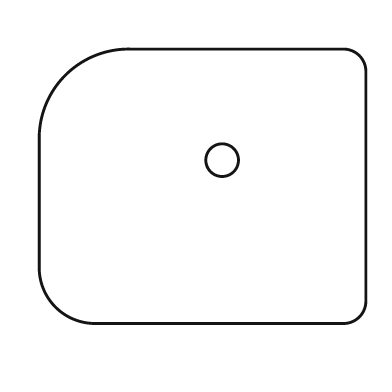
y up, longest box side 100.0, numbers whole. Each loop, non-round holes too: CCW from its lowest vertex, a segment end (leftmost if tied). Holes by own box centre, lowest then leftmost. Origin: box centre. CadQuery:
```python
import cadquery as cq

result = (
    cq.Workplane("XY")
    .moveTo(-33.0, -42.0)
    .lineTo(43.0, -42.0)
    .threePointArc((48.0, -40.0), (50.0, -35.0))
    .lineTo(50.0, 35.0)
    .threePointArc((48.0, 40.0), (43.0, 42.0))
    .lineTo(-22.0, 42.0)
    .threePointArc((-42.0, 34.0), (-50.0, 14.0))
    .lineTo(-50.0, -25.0)
    .threePointArc((-45.0, -37.0), (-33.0, -42.0))
    .close()
    .moveTo(6.0, 8.0)
    .circle(5.0)
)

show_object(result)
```